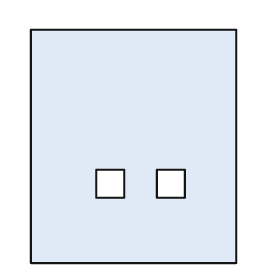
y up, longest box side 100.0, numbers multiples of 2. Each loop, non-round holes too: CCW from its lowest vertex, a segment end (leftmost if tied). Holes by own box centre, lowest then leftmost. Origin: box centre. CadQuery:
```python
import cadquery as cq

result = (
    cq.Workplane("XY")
    .moveTo(-44.0, -50.0)
    .lineTo(44.0, -50.0)
    .lineTo(44.0, 50.0)
    .lineTo(-44.0, 50.0)
    .close()
    .moveTo(-16.0, -22.0)
    .lineTo(-4.0, -22.0)
    .lineTo(-4.0, -10.0)
    .lineTo(-16.0, -10.0)
    .close()
    .moveTo(10.0, -22.0)
    .lineTo(22.0, -22.0)
    .lineTo(22.0, -10.0)
    .lineTo(10.0, -10.0)
    .close()
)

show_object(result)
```